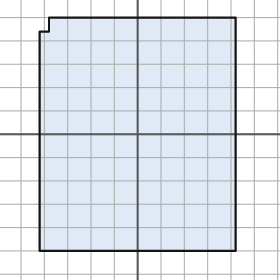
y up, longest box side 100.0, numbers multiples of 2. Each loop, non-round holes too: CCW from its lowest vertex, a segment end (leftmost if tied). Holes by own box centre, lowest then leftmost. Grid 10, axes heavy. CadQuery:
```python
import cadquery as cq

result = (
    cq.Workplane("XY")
    .moveTo(-42.0, -50.0)
    .lineTo(42.0, -50.0)
    .lineTo(42.0, 50.0)
    .lineTo(-38.0, 50.0)
    .lineTo(-38.0, 44.0)
    .lineTo(-42.0, 44.0)
    .close()
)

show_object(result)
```